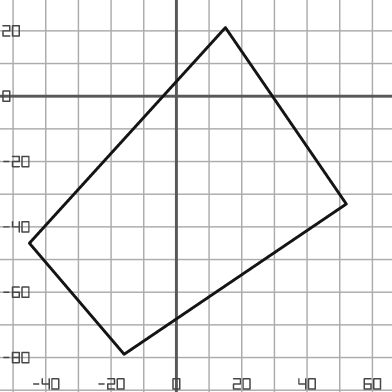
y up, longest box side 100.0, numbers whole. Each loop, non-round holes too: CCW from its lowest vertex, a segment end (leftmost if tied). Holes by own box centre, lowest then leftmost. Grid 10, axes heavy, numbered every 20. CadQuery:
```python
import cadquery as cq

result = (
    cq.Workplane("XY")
    .moveTo(-16.0, -79.0)
    .lineTo(52.0, -33.0)
    .lineTo(15.0, 21.0)
    .lineTo(-45.0, -45.0)
    .close()
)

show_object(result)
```